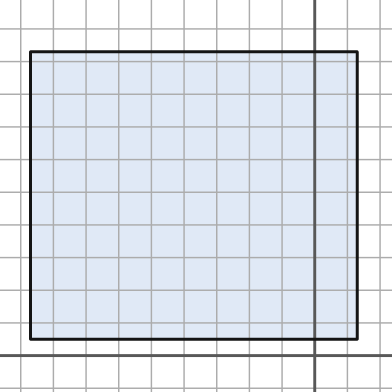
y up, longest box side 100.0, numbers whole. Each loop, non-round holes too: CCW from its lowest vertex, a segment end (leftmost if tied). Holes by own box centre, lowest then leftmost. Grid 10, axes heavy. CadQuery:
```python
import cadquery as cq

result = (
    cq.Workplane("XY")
    .moveTo(-87.0, 5.0)
    .lineTo(13.0, 5.0)
    .lineTo(13.0, 93.0)
    .lineTo(-87.0, 93.0)
    .close()
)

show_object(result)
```